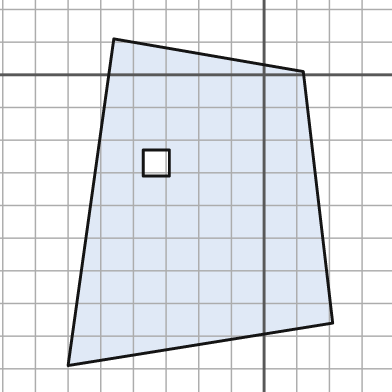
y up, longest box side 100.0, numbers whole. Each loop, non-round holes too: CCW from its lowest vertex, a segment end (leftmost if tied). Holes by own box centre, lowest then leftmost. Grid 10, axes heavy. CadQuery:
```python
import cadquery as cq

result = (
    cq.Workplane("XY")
    .moveTo(-60.0, -89.0)
    .lineTo(21.0, -76.0)
    .lineTo(12.0, 1.0)
    .lineTo(-46.0, 11.0)
    .close()
    .moveTo(-37.0, -31.0)
    .lineTo(-29.0, -31.0)
    .lineTo(-29.0, -23.0)
    .lineTo(-37.0, -23.0)
    .close()
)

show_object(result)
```